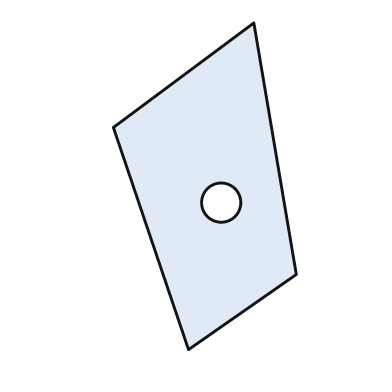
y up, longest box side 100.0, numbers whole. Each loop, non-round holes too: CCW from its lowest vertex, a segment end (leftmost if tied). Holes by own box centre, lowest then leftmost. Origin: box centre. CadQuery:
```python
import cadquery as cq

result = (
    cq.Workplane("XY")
    .moveTo(-5.0, -50.0)
    .lineTo(28.0, -27.0)
    .lineTo(15.0, 50.0)
    .lineTo(-28.0, 18.0)
    .close()
    .moveTo(5.0, -5.0)
    .circle(6.0)
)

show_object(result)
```